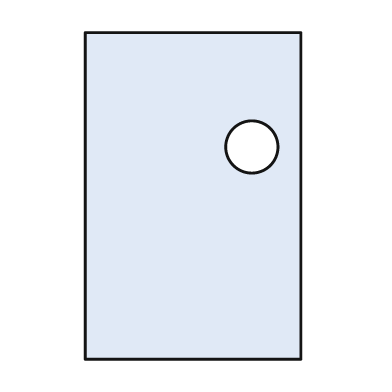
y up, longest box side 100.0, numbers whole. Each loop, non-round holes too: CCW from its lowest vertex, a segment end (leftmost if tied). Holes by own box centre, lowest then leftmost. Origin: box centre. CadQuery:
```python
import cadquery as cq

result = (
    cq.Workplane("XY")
    .moveTo(-33.0, -50.0)
    .lineTo(33.0, -50.0)
    .lineTo(33.0, 50.0)
    .lineTo(-33.0, 50.0)
    .close()
    .moveTo(18.0, 15.0)
    .circle(8.0)
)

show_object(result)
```